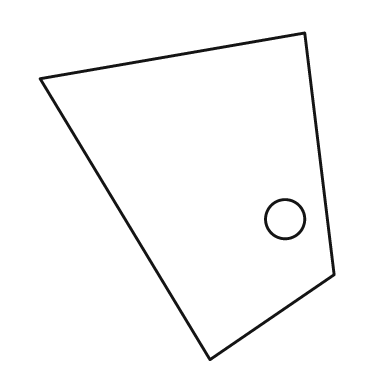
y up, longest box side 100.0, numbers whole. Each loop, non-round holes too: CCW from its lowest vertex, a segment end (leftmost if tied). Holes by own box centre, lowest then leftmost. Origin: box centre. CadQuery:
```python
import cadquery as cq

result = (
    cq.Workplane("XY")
    .moveTo(7.0, -50.0)
    .lineTo(45.0, -24.0)
    .lineTo(36.0, 50.0)
    .lineTo(-45.0, 36.0)
    .close()
    .moveTo(30.0, -7.0)
    .circle(6.0)
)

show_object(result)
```